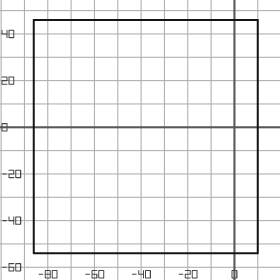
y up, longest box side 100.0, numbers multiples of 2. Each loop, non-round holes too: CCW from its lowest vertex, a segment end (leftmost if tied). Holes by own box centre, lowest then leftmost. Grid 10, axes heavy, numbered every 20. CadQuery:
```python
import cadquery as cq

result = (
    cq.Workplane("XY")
    .moveTo(-86.0, -54.0)
    .lineTo(10.0, -54.0)
    .lineTo(10.0, 46.0)
    .lineTo(-86.0, 46.0)
    .close()
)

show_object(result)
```